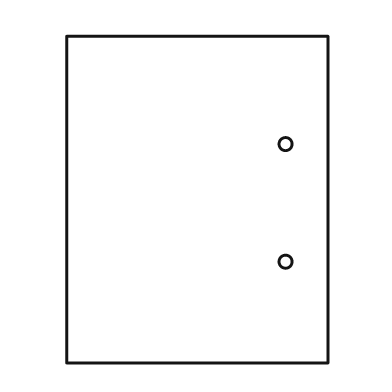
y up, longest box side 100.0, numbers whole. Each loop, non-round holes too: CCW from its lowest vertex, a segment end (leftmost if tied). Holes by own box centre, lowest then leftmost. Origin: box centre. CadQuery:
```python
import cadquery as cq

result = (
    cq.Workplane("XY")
    .moveTo(-40.0, -50.0)
    .lineTo(40.0, -50.0)
    .lineTo(40.0, 50.0)
    .lineTo(-40.0, 50.0)
    .close()
    .moveTo(27.0, -19.0)
    .circle(2.0)
    .moveTo(27.0, 17.0)
    .circle(2.0)
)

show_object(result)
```